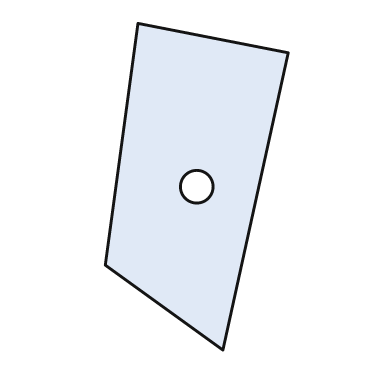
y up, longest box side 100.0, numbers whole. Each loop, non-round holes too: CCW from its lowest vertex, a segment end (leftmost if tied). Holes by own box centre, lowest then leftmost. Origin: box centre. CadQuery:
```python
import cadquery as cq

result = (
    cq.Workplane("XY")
    .moveTo(8.0, -50.0)
    .lineTo(28.0, 41.0)
    .lineTo(-18.0, 50.0)
    .lineTo(-28.0, -24.0)
    .close()
    .moveTo(0.0, 0.0)
    .circle(5.0)
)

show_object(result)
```